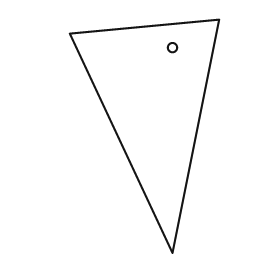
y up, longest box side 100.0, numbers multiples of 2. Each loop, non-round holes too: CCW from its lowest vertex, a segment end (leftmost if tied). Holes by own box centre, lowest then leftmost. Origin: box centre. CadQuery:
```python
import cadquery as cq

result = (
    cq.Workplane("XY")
    .moveTo(12.0, -50.0)
    .lineTo(32.0, 50.0)
    .lineTo(-32.0, 44.0)
    .close()
    .moveTo(12.0, 38.0)
    .circle(2.0)
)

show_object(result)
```